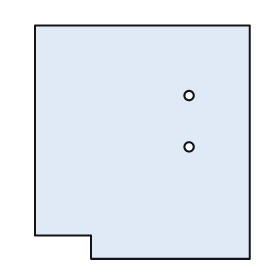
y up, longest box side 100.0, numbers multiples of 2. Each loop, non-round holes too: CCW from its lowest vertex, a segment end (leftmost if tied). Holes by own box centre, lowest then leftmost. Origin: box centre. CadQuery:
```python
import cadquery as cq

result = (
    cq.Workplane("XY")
    .moveTo(-22.0, -50.0)
    .lineTo(46.0, -50.0)
    .lineTo(46.0, 50.0)
    .lineTo(-46.0, 50.0)
    .lineTo(-46.0, -40.0)
    .lineTo(-22.0, -40.0)
    .close()
    .moveTo(20.0, -2.0)
    .circle(2.0)
    .moveTo(20.0, 20.0)
    .circle(2.0)
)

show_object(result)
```